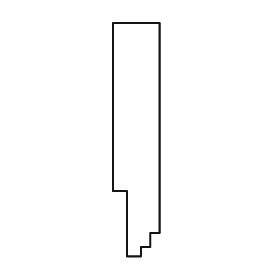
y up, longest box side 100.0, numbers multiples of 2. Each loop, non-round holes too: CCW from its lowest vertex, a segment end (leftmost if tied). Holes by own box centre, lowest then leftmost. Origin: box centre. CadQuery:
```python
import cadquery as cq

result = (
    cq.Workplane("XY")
    .moveTo(-4.0, -50.0)
    .lineTo(2.0, -50.0)
    .lineTo(2.0, -46.0)
    .lineTo(6.0, -46.0)
    .lineTo(6.0, -40.0)
    .lineTo(10.0, -40.0)
    .lineTo(10.0, 50.0)
    .lineTo(-10.0, 50.0)
    .lineTo(-10.0, -22.0)
    .lineTo(-4.0, -22.0)
    .close()
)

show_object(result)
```